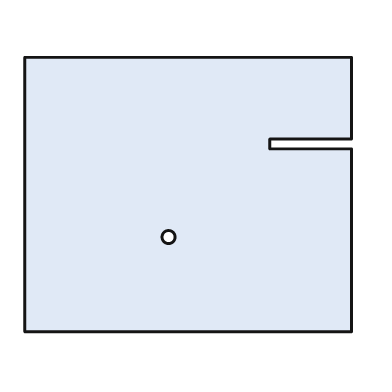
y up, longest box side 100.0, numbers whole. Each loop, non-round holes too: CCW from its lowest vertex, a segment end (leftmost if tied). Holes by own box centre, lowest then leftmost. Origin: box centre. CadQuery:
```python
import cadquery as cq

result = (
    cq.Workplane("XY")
    .moveTo(-50.0, -42.0)
    .lineTo(50.0, -42.0)
    .lineTo(50.0, 14.0)
    .lineTo(25.0, 14.0)
    .lineTo(25.0, 17.0)
    .lineTo(50.0, 17.0)
    .lineTo(50.0, 42.0)
    .lineTo(-50.0, 42.0)
    .close()
    .moveTo(-6.0, -13.0)
    .circle(2.0)
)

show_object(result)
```